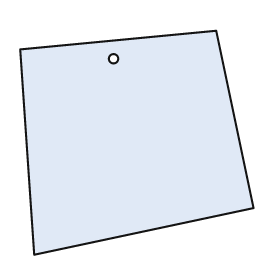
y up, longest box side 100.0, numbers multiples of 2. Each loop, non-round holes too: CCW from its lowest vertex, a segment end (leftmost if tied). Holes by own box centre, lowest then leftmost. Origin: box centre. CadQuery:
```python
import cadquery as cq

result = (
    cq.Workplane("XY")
    .moveTo(-44.0, -48.0)
    .lineTo(50.0, -28.0)
    .lineTo(34.0, 48.0)
    .lineTo(-50.0, 40.0)
    .close()
    .moveTo(-10.0, 36.0)
    .circle(2.0)
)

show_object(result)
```